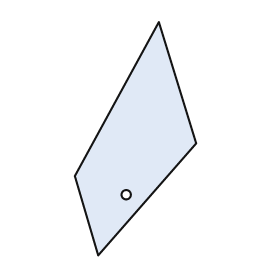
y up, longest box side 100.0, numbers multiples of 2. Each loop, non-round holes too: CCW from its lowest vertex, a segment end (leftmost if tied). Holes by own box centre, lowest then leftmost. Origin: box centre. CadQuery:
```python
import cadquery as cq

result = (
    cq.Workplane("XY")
    .moveTo(-16.0, -50.0)
    .lineTo(26.0, -2.0)
    .lineTo(10.0, 50.0)
    .lineTo(-26.0, -16.0)
    .close()
    .moveTo(-4.0, -24.0)
    .circle(2.0)
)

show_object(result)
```